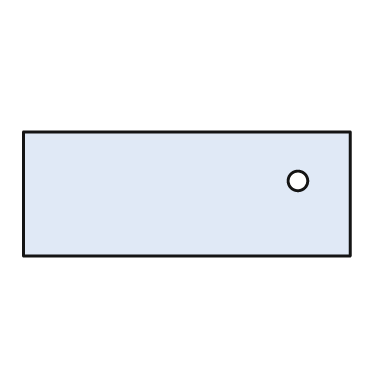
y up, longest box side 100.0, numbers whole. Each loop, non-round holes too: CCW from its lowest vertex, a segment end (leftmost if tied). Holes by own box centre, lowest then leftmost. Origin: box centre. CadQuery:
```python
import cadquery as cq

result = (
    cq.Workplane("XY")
    .moveTo(-50.0, -19.0)
    .lineTo(50.0, -19.0)
    .lineTo(50.0, 19.0)
    .lineTo(-50.0, 19.0)
    .close()
    .moveTo(34.0, 4.0)
    .circle(3.0)
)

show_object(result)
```